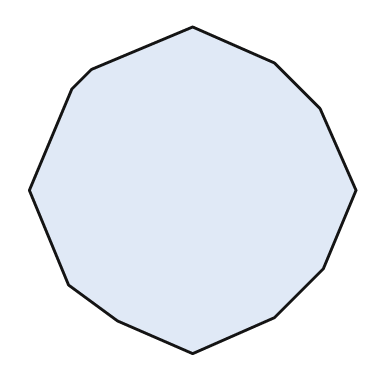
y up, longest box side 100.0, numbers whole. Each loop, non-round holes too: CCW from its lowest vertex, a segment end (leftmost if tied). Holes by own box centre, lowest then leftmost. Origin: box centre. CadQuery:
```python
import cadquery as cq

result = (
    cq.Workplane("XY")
    .moveTo(0.0, -50.0)
    .lineTo(25.0, -39.0)
    .lineTo(40.0, -24.0)
    .lineTo(50.0, 0.0)
    .lineTo(39.0, 25.0)
    .lineTo(25.0, 39.0)
    .lineTo(0.0, 50.0)
    .lineTo(-31.0, 37.0)
    .lineTo(-37.0, 31.0)
    .lineTo(-50.0, 0.0)
    .lineTo(-38.0, -29.0)
    .lineTo(-23.0, -40.0)
    .close()
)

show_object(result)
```